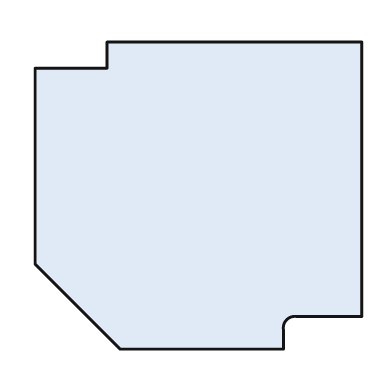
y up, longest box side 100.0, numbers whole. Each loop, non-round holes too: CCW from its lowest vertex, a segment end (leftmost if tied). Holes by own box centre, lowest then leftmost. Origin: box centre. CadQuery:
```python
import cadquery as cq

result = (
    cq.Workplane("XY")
    .moveTo(-24.0, -47.0)
    .lineTo(26.0, -47.0)
    .lineTo(26.0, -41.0)
    .threePointArc((27.0, -38.0), (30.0, -37.0))
    .lineTo(50.0, -37.0)
    .lineTo(50.0, 47.0)
    .lineTo(-28.0, 47.0)
    .lineTo(-28.0, 39.0)
    .lineTo(-50.0, 39.0)
    .lineTo(-50.0, -21.0)
    .close()
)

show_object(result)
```